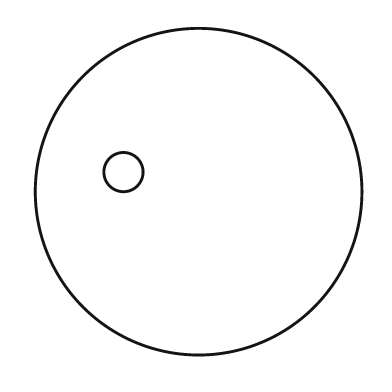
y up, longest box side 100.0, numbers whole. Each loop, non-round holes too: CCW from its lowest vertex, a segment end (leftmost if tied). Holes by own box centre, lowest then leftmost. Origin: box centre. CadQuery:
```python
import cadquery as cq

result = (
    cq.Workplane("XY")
    .moveTo(0.0, 0.0)
    .circle(50.0)
    .moveTo(-23.0, 6.0)
    .circle(6.0)
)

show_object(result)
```